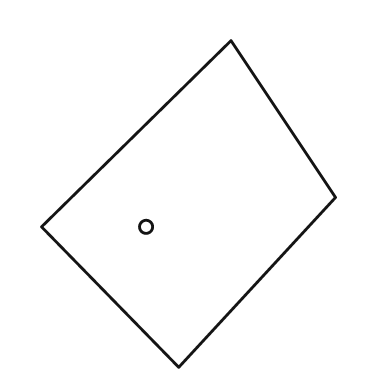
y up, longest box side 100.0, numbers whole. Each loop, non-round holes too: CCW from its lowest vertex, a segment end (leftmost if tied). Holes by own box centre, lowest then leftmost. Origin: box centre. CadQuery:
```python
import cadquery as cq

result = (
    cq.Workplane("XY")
    .moveTo(-3.0, -50.0)
    .lineTo(45.0, 2.0)
    .lineTo(13.0, 50.0)
    .lineTo(-45.0, -7.0)
    .close()
    .moveTo(-13.0, -7.0)
    .circle(2.0)
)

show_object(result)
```